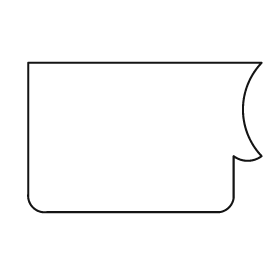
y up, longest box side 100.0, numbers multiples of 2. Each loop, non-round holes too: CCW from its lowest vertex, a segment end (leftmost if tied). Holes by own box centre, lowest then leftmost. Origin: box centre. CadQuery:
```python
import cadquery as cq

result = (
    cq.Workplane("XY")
    .moveTo(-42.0, -32.0)
    .lineTo(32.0, -32.0)
    .threePointArc((36.0, -30.0), (38.0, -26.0))
    .lineTo(38.0, -8.0)
    .threePointArc((44.0, -10.0), (50.0, -8.0))
    .threePointArc((42.0, 12.0), (50.0, 32.0))
    .lineTo(-50.0, 32.0)
    .lineTo(-50.0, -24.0)
    .threePointArc((-48.0, -30.0), (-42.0, -32.0))
    .close()
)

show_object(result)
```